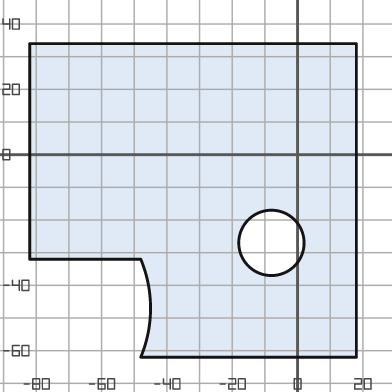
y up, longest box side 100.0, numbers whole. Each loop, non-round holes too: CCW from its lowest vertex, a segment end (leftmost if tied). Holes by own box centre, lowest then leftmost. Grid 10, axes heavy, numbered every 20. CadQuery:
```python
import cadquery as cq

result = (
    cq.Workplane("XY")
    .moveTo(-48.0, -62.0)
    .lineTo(18.0, -62.0)
    .lineTo(18.0, 34.0)
    .lineTo(-82.0, 34.0)
    .lineTo(-82.0, -32.0)
    .lineTo(-48.0, -32.0)
    .threePointArc((-45.0, -47.0), (-48.0, -62.0))
    .close()
    .moveTo(-8.0, -27.0)
    .circle(10.0)
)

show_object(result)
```